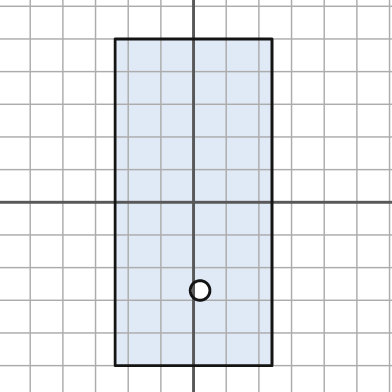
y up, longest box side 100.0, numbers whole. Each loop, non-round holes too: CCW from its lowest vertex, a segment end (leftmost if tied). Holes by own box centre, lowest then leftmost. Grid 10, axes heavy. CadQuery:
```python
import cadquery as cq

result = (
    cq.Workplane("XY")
    .moveTo(-24.0, -50.0)
    .lineTo(24.0, -50.0)
    .lineTo(24.0, 50.0)
    .lineTo(-24.0, 50.0)
    .close()
    .moveTo(2.0, -27.0)
    .circle(3.0)
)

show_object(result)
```